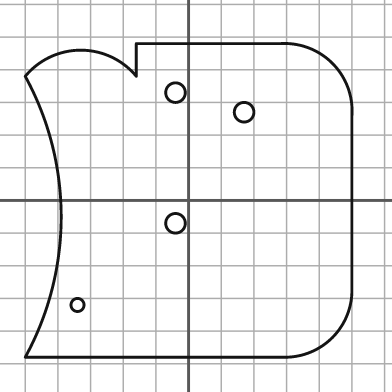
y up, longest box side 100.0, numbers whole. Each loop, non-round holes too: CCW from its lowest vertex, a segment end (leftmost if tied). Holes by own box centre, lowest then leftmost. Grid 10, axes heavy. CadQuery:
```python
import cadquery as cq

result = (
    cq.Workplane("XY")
    .moveTo(-50.0, -48.0)
    .lineTo(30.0, -48.0)
    .threePointArc((44.0, -42.0), (50.0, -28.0))
    .lineTo(50.0, 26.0)
    .threePointArc((44.0, 42.0), (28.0, 48.0))
    .lineTo(-16.0, 48.0)
    .lineTo(-16.0, 38.0)
    .threePointArc((-33.0, 46.0), (-50.0, 38.0))
    .threePointArc((-39.0, -5.0), (-50.0, -48.0))
    .close()
    .moveTo(-34.0, -32.0)
    .circle(2.0)
    .moveTo(-4.0, -7.0)
    .circle(3.0)
    .moveTo(17.0, 27.0)
    .circle(3.0)
    .moveTo(-4.0, 33.0)
    .circle(3.0)
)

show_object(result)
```